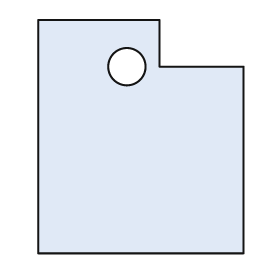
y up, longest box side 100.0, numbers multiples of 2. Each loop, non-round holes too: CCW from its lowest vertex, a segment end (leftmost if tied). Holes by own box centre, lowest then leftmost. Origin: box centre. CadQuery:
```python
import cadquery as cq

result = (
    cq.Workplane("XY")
    .moveTo(-44.0, -50.0)
    .lineTo(44.0, -50.0)
    .lineTo(44.0, 30.0)
    .lineTo(8.0, 30.0)
    .lineTo(8.0, 50.0)
    .lineTo(-44.0, 50.0)
    .close()
    .moveTo(-6.0, 30.0)
    .circle(8.0)
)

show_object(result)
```